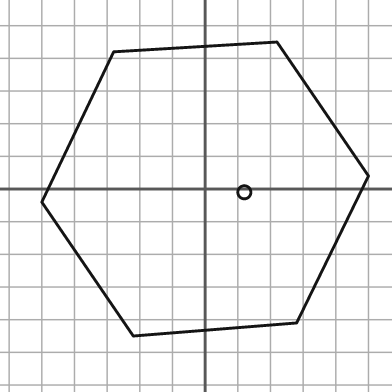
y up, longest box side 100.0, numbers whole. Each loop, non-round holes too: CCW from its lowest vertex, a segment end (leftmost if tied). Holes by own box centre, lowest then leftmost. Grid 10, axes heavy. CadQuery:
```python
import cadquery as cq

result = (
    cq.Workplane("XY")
    .moveTo(-22.0, -45.0)
    .lineTo(28.0, -41.0)
    .lineTo(50.0, 4.0)
    .lineTo(22.0, 45.0)
    .lineTo(-28.0, 42.0)
    .lineTo(-50.0, -4.0)
    .close()
    .moveTo(12.0, -1.0)
    .circle(2.0)
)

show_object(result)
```